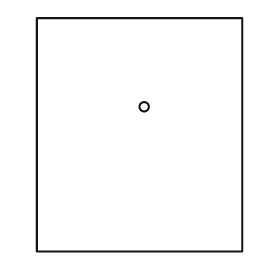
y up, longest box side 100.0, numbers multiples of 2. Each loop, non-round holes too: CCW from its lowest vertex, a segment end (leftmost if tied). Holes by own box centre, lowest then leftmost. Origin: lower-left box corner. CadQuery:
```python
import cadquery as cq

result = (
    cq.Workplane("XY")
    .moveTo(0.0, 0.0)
    .lineTo(88.0, 0.0)
    .lineTo(88.0, 100.0)
    .lineTo(0.0, 100.0)
    .close()
    .moveTo(46.0, 62.0)
    .circle(2.0)
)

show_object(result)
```